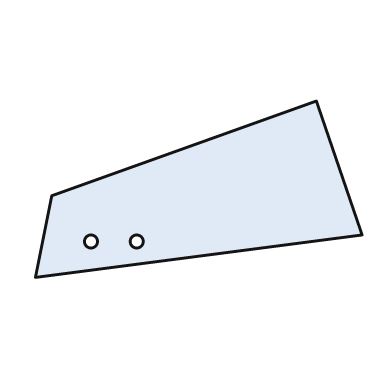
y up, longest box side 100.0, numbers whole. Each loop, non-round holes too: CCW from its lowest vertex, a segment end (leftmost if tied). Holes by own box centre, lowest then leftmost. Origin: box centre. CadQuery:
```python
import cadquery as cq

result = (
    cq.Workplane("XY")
    .moveTo(-50.0, -27.0)
    .lineTo(50.0, -14.0)
    .lineTo(36.0, 27.0)
    .lineTo(-45.0, -2.0)
    .close()
    .moveTo(-33.0, -16.0)
    .circle(2.0)
    .moveTo(-19.0, -16.0)
    .circle(2.0)
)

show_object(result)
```